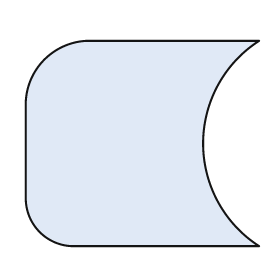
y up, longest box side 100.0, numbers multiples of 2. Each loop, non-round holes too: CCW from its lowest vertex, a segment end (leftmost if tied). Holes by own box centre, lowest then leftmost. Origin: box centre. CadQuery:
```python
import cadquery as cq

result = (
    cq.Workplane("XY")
    .moveTo(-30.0, -44.0)
    .lineTo(50.0, -44.0)
    .threePointArc((26.0, 0.0), (50.0, 44.0))
    .lineTo(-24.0, 44.0)
    .threePointArc((-42.0, 36.0), (-50.0, 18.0))
    .lineTo(-50.0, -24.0)
    .threePointArc((-44.0, -38.0), (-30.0, -44.0))
    .close()
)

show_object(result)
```